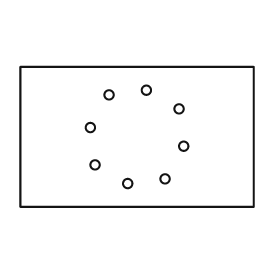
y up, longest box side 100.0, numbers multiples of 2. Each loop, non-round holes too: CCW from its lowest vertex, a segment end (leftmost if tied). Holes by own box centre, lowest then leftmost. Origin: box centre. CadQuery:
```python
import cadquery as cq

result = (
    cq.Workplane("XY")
    .moveTo(-50.0, -30.0)
    .lineTo(50.0, -30.0)
    .lineTo(50.0, 30.0)
    .lineTo(-50.0, 30.0)
    .close()
    .moveTo(-4.0, -20.0)
    .circle(2.0)
    .moveTo(12.0, -18.0)
    .circle(2.0)
    .moveTo(-18.0, -12.0)
    .circle(2.0)
    .moveTo(20.0, -4.0)
    .circle(2.0)
    .moveTo(-20.0, 4.0)
    .circle(2.0)
    .moveTo(18.0, 12.0)
    .circle(2.0)
    .moveTo(-12.0, 18.0)
    .circle(2.0)
    .moveTo(4.0, 20.0)
    .circle(2.0)
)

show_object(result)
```